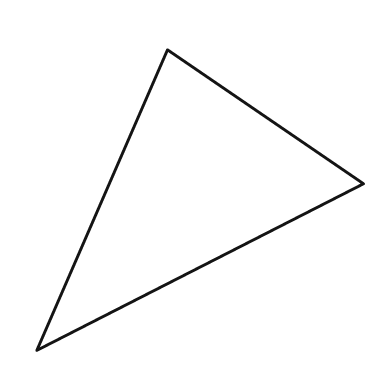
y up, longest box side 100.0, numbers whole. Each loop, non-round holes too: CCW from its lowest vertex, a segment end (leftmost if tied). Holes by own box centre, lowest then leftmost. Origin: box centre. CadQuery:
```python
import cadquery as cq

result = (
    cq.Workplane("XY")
    .moveTo(-50.0, -46.0)
    .lineTo(50.0, 5.0)
    .lineTo(-10.0, 46.0)
    .close()
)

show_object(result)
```